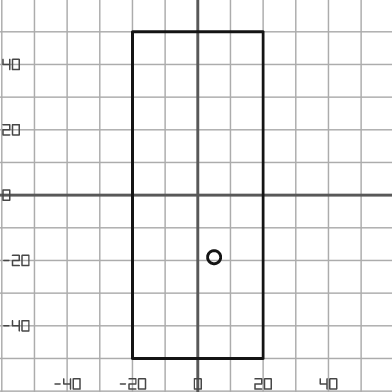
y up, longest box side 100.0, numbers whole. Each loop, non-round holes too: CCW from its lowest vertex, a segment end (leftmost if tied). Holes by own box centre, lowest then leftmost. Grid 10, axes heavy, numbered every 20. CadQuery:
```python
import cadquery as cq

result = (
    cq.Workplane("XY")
    .moveTo(-20.0, -50.0)
    .lineTo(20.0, -50.0)
    .lineTo(20.0, 50.0)
    .lineTo(-20.0, 50.0)
    .close()
    .moveTo(5.0, -19.0)
    .circle(2.0)
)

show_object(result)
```